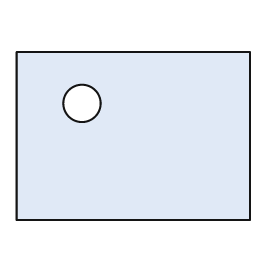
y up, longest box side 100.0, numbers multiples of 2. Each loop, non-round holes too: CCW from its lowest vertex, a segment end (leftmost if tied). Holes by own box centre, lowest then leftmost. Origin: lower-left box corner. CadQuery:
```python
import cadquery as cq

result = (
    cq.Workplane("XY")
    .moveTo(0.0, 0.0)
    .lineTo(100.0, 0.0)
    .lineTo(100.0, 72.0)
    .lineTo(0.0, 72.0)
    .close()
    .moveTo(28.0, 50.0)
    .circle(8.0)
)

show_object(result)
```